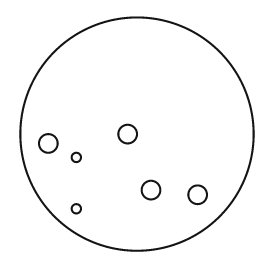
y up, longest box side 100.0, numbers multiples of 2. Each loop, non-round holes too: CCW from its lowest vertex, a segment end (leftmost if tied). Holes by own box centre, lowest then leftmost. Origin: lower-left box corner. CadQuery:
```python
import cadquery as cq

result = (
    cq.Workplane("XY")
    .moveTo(50.0, 50.0)
    .circle(50.0)
    .moveTo(24.0, 18.0)
    .circle(2.0)
    .moveTo(76.0, 24.0)
    .circle(4.0)
    .moveTo(56.0, 26.0)
    .circle(4.0)
    .moveTo(24.0, 40.0)
    .circle(2.0)
    .moveTo(12.0, 46.0)
    .circle(4.0)
    .moveTo(46.0, 50.0)
    .circle(4.0)
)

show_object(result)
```